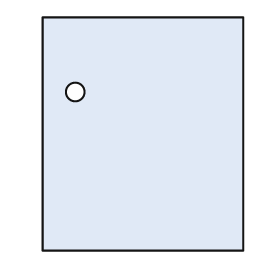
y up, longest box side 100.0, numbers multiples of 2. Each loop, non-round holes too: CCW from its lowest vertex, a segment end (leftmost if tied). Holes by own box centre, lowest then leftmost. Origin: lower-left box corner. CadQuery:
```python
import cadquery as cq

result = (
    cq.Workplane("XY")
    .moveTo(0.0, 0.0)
    .lineTo(86.0, 0.0)
    .lineTo(86.0, 100.0)
    .lineTo(0.0, 100.0)
    .close()
    .moveTo(14.0, 68.0)
    .circle(4.0)
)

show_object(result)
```